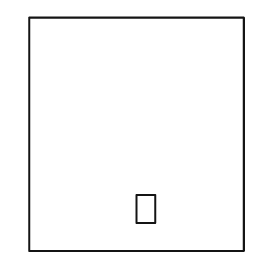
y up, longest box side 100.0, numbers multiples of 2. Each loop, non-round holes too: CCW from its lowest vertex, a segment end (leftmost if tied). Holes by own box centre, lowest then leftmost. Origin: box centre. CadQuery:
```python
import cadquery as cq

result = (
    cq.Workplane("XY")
    .moveTo(-46.0, -50.0)
    .lineTo(46.0, -50.0)
    .lineTo(46.0, 50.0)
    .lineTo(-46.0, 50.0)
    .close()
    .moveTo(0.0, -38.0)
    .lineTo(8.0, -38.0)
    .lineTo(8.0, -26.0)
    .lineTo(0.0, -26.0)
    .close()
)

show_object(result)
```